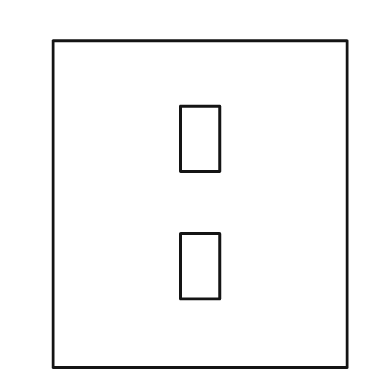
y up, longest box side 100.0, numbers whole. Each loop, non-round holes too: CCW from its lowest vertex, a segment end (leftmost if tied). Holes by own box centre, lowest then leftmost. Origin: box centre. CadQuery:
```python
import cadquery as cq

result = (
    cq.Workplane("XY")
    .moveTo(-45.0, -50.0)
    .lineTo(45.0, -50.0)
    .lineTo(45.0, 50.0)
    .lineTo(-45.0, 50.0)
    .close()
    .moveTo(-6.0, -29.0)
    .lineTo(6.0, -29.0)
    .lineTo(6.0, -9.0)
    .lineTo(-6.0, -9.0)
    .close()
    .moveTo(-6.0, 10.0)
    .lineTo(6.0, 10.0)
    .lineTo(6.0, 30.0)
    .lineTo(-6.0, 30.0)
    .close()
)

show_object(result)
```